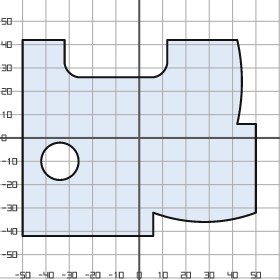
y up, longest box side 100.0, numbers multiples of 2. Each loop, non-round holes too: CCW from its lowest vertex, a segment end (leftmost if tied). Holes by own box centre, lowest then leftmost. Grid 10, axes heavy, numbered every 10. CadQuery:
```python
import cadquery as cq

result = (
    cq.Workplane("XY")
    .moveTo(-50.0, -42.0)
    .lineTo(6.0, -42.0)
    .lineTo(6.0, -32.0)
    .threePointArc((28.0, -36.0), (50.0, -32.0))
    .lineTo(50.0, 6.0)
    .lineTo(42.0, 6.0)
    .threePointArc((44.0, 24.0), (42.0, 42.0))
    .lineTo(12.0, 42.0)
    .lineTo(12.0, 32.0)
    .threePointArc((10.0, 28.0), (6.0, 26.0))
    .lineTo(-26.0, 26.0)
    .threePointArc((-30.0, 28.0), (-32.0, 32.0))
    .lineTo(-32.0, 42.0)
    .lineTo(-50.0, 42.0)
    .close()
    .moveTo(-34.0, -10.0)
    .circle(8.0)
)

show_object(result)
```